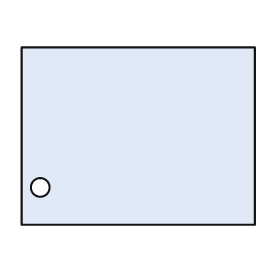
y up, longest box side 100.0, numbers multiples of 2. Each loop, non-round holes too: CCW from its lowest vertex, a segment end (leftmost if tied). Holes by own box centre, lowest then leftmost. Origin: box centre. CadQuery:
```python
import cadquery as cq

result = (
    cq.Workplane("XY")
    .moveTo(-50.0, -38.0)
    .lineTo(50.0, -38.0)
    .lineTo(50.0, 38.0)
    .lineTo(-50.0, 38.0)
    .close()
    .moveTo(-42.0, -22.0)
    .circle(4.0)
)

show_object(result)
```